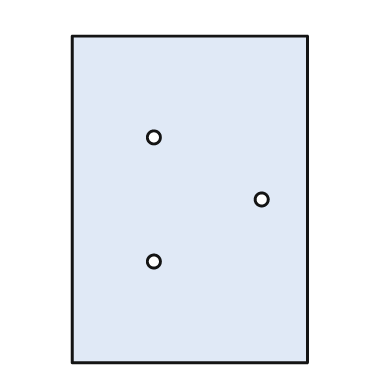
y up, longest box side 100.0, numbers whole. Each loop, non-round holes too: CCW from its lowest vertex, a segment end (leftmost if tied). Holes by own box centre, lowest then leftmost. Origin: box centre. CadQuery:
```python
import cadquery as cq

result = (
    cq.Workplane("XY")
    .moveTo(-36.0, -50.0)
    .lineTo(36.0, -50.0)
    .lineTo(36.0, 50.0)
    .lineTo(-36.0, 50.0)
    .close()
    .moveTo(-11.0, -19.0)
    .circle(2.0)
    .moveTo(22.0, 0.0)
    .circle(2.0)
    .moveTo(-11.0, 19.0)
    .circle(2.0)
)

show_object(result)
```